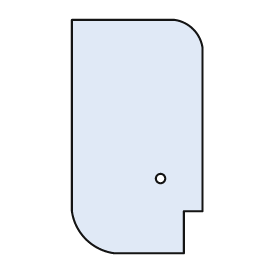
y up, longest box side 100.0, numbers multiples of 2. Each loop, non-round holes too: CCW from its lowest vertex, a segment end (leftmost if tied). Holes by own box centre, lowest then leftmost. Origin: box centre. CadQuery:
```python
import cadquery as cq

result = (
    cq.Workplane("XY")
    .moveTo(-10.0, -50.0)
    .lineTo(20.0, -50.0)
    .lineTo(20.0, -32.0)
    .lineTo(28.0, -32.0)
    .lineTo(28.0, 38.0)
    .threePointArc((24.0, 46.0), (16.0, 50.0))
    .lineTo(-28.0, 50.0)
    .lineTo(-28.0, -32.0)
    .threePointArc((-22.0, -44.0), (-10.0, -50.0))
    .close()
    .moveTo(10.0, -18.0)
    .circle(2.0)
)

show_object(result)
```